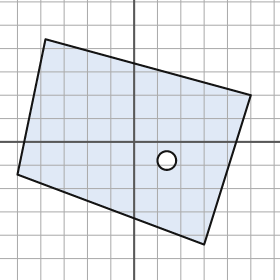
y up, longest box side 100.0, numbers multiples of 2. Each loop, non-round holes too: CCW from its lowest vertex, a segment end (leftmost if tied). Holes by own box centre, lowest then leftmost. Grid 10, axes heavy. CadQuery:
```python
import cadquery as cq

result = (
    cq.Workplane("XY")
    .moveTo(30.0, -44.0)
    .lineTo(50.0, 20.0)
    .lineTo(-38.0, 44.0)
    .lineTo(-50.0, -14.0)
    .close()
    .moveTo(14.0, -8.0)
    .circle(4.0)
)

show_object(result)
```